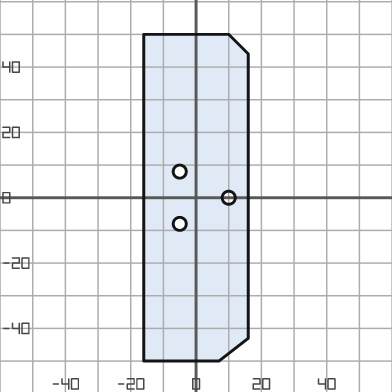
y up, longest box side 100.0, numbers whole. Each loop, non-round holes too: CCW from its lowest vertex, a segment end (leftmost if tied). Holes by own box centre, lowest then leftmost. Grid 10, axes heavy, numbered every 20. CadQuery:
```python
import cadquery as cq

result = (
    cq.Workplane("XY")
    .moveTo(-16.0, -50.0)
    .lineTo(7.0, -50.0)
    .lineTo(16.0, -43.0)
    .lineTo(16.0, 44.0)
    .lineTo(10.0, 50.0)
    .lineTo(-16.0, 50.0)
    .close()
    .moveTo(-5.0, -8.0)
    .circle(2.0)
    .moveTo(10.0, 0.0)
    .circle(2.0)
    .moveTo(-5.0, 8.0)
    .circle(2.0)
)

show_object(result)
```